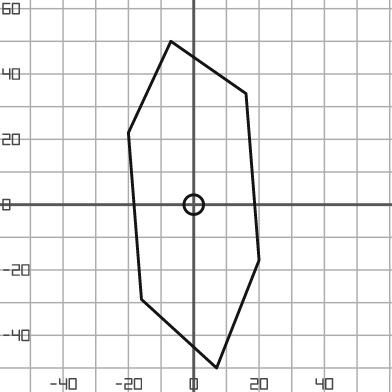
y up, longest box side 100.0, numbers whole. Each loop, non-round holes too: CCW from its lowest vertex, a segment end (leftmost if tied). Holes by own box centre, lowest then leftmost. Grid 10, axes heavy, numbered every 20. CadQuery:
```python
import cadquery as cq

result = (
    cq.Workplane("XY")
    .moveTo(7.0, -50.0)
    .lineTo(20.0, -17.0)
    .lineTo(16.0, 34.0)
    .lineTo(-7.0, 50.0)
    .lineTo(-20.0, 22.0)
    .lineTo(-16.0, -29.0)
    .close()
    .moveTo(0.0, 0.0)
    .circle(3.0)
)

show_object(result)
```